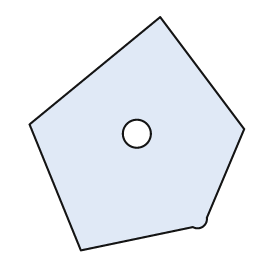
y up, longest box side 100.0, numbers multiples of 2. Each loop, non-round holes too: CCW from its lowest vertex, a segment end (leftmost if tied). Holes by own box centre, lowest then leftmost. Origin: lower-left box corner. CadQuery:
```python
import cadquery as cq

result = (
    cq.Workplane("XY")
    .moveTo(22.0, 0.0)
    .lineTo(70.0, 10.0)
    .threePointArc((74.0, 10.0), (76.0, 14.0))
    .lineTo(92.0, 52.0)
    .lineTo(56.0, 100.0)
    .lineTo(0.0, 54.0)
    .close()
    .moveTo(46.0, 50.0)
    .circle(6.0)
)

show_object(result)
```